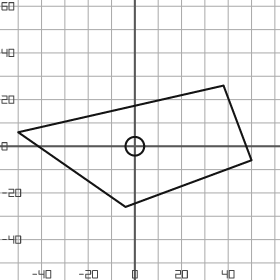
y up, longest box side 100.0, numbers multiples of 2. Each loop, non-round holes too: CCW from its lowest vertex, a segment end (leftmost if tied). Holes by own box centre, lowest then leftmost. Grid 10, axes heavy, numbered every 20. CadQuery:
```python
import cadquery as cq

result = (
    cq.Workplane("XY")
    .moveTo(-4.0, -26.0)
    .lineTo(50.0, -6.0)
    .lineTo(38.0, 26.0)
    .lineTo(-50.0, 6.0)
    .close()
    .moveTo(0.0, 0.0)
    .circle(4.0)
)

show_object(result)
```